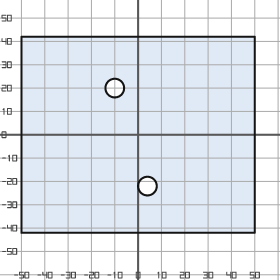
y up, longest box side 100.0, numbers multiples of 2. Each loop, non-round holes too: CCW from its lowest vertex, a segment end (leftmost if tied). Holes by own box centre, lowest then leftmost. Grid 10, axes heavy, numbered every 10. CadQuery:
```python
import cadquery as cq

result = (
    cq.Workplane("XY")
    .moveTo(-50.0, -42.0)
    .lineTo(50.0, -42.0)
    .lineTo(50.0, 42.0)
    .lineTo(-50.0, 42.0)
    .close()
    .moveTo(4.0, -22.0)
    .circle(4.0)
    .moveTo(-10.0, 20.0)
    .circle(4.0)
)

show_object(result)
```